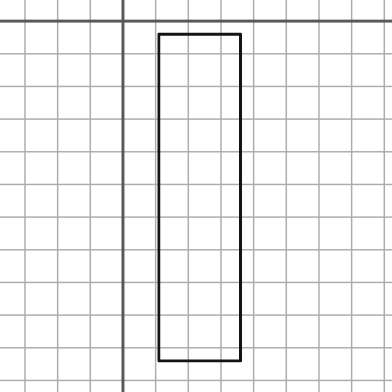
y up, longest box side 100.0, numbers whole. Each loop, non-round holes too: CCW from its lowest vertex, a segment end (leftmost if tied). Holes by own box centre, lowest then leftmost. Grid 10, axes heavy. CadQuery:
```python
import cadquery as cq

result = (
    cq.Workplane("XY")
    .moveTo(11.0, -104.0)
    .lineTo(36.0, -104.0)
    .lineTo(36.0, -4.0)
    .lineTo(11.0, -4.0)
    .close()
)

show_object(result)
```